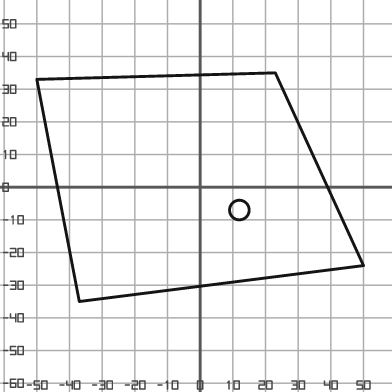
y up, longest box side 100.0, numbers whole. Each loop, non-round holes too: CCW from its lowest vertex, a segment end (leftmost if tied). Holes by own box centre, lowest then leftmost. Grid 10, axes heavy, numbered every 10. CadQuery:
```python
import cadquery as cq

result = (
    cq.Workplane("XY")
    .moveTo(-37.0, -35.0)
    .lineTo(50.0, -24.0)
    .lineTo(23.0, 35.0)
    .lineTo(-50.0, 33.0)
    .close()
    .moveTo(12.0, -7.0)
    .circle(3.0)
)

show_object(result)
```